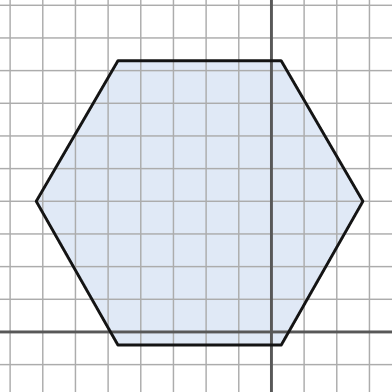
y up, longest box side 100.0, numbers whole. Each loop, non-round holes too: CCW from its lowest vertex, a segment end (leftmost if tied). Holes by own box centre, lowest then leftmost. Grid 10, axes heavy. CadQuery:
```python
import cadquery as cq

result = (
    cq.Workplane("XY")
    .moveTo(-47.0, -4.0)
    .lineTo(3.0, -4.0)
    .lineTo(28.0, 40.0)
    .lineTo(3.0, 83.0)
    .lineTo(-47.0, 83.0)
    .lineTo(-72.0, 40.0)
    .close()
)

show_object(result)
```